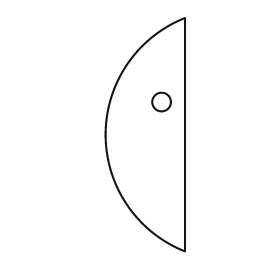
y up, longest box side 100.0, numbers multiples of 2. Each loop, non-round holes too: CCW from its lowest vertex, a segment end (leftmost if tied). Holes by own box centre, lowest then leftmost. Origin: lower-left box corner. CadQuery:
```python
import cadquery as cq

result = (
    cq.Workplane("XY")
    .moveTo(34.0, 0.0)
    .lineTo(34.0, 100.0)
    .threePointArc((0.0, 50.0), (34.0, 0.0))
    .close()
    .moveTo(24.0, 64.0)
    .circle(4.0)
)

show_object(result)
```